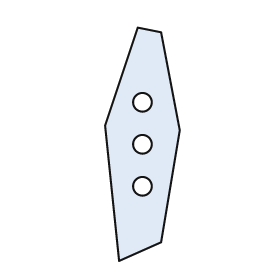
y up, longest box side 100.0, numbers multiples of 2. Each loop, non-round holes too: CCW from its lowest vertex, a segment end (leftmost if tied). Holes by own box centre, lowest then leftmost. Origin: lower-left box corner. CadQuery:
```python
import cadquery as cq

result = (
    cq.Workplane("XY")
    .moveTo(6.0, 0.0)
    .lineTo(24.0, 8.0)
    .lineTo(32.0, 56.0)
    .lineTo(24.0, 98.0)
    .lineTo(14.0, 100.0)
    .lineTo(0.0, 58.0)
    .close()
    .moveTo(16.0, 32.0)
    .circle(4.0)
    .moveTo(16.0, 50.0)
    .circle(4.0)
    .moveTo(16.0, 68.0)
    .circle(4.0)
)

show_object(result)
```